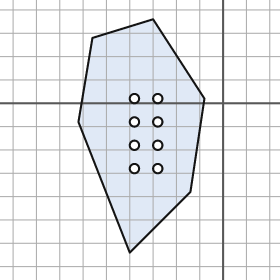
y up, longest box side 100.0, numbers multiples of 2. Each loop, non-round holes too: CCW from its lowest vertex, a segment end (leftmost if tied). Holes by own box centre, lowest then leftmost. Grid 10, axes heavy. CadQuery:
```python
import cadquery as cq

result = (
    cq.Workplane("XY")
    .moveTo(-40.0, -64.0)
    .lineTo(-14.0, -38.0)
    .lineTo(-8.0, 2.0)
    .lineTo(-30.0, 36.0)
    .lineTo(-56.0, 28.0)
    .lineTo(-62.0, -8.0)
    .close()
    .moveTo(-38.0, -28.0)
    .circle(2.0)
    .moveTo(-28.0, -28.0)
    .circle(2.0)
    .moveTo(-38.0, -18.0)
    .circle(2.0)
    .moveTo(-28.0, -18.0)
    .circle(2.0)
    .moveTo(-38.0, -8.0)
    .circle(2.0)
    .moveTo(-28.0, -8.0)
    .circle(2.0)
    .moveTo(-38.0, 2.0)
    .circle(2.0)
    .moveTo(-28.0, 2.0)
    .circle(2.0)
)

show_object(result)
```